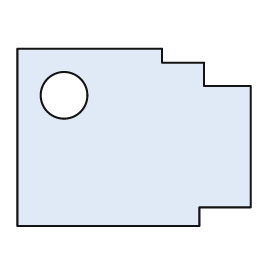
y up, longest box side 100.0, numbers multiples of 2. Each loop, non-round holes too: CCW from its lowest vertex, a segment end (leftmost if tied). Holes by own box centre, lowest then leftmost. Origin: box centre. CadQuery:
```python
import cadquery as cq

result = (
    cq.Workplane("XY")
    .moveTo(-50.0, -38.0)
    .lineTo(28.0, -38.0)
    .lineTo(28.0, -30.0)
    .lineTo(50.0, -30.0)
    .lineTo(50.0, 22.0)
    .lineTo(30.0, 22.0)
    .lineTo(30.0, 32.0)
    .lineTo(12.0, 32.0)
    .lineTo(12.0, 38.0)
    .lineTo(-50.0, 38.0)
    .close()
    .moveTo(-30.0, 18.0)
    .circle(10.0)
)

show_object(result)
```